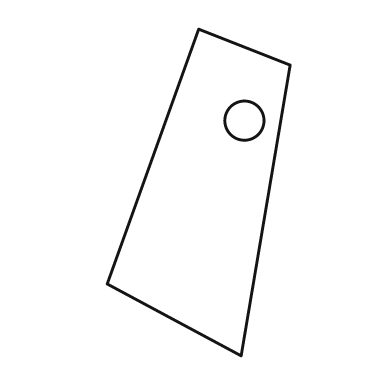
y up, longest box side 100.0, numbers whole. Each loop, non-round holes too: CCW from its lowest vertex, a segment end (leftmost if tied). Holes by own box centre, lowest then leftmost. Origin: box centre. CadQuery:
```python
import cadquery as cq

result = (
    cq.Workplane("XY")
    .moveTo(13.0, -50.0)
    .lineTo(28.0, 39.0)
    .lineTo(0.0, 50.0)
    .lineTo(-28.0, -28.0)
    .close()
    .moveTo(14.0, 22.0)
    .circle(6.0)
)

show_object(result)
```